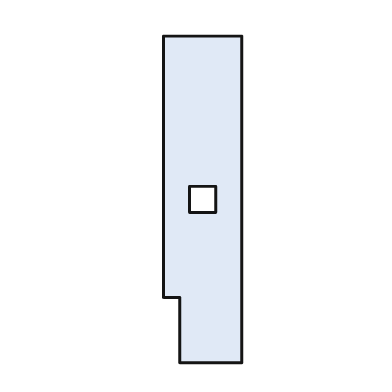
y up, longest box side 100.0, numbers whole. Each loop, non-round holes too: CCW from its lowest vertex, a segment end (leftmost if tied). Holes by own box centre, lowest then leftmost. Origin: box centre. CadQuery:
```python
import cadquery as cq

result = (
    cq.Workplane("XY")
    .moveTo(-7.0, -50.0)
    .lineTo(12.0, -50.0)
    .lineTo(12.0, 50.0)
    .lineTo(-12.0, 50.0)
    .lineTo(-12.0, -30.0)
    .lineTo(-7.0, -30.0)
    .close()
    .moveTo(-4.0, -4.0)
    .lineTo(4.0, -4.0)
    .lineTo(4.0, 4.0)
    .lineTo(-4.0, 4.0)
    .close()
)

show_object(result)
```